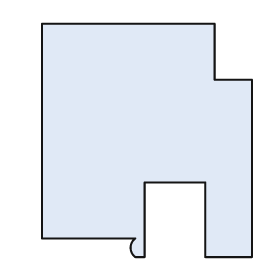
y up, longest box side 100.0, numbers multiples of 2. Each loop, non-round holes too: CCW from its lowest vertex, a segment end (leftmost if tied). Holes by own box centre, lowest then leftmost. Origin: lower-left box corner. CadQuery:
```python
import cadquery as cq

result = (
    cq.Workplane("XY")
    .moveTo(40.0, 0.0)
    .lineTo(44.0, 0.0)
    .lineTo(44.0, 32.0)
    .lineTo(70.0, 32.0)
    .lineTo(70.0, 0.0)
    .lineTo(90.0, 0.0)
    .lineTo(90.0, 76.0)
    .lineTo(74.0, 76.0)
    .lineTo(74.0, 100.0)
    .lineTo(0.0, 100.0)
    .lineTo(0.0, 8.0)
    .lineTo(40.0, 8.0)
    .threePointArc((38.0, 4.0), (40.0, 0.0))
    .close()
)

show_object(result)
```